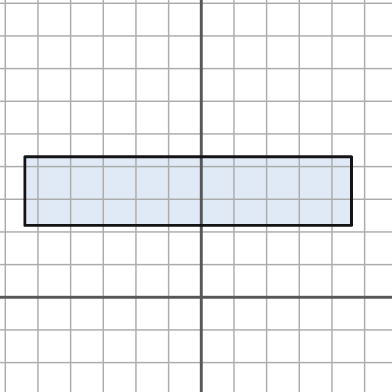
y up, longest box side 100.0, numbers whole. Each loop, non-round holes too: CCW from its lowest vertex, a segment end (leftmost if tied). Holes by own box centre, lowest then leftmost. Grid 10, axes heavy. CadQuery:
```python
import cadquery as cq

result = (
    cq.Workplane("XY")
    .moveTo(-54.0, 22.0)
    .lineTo(46.0, 22.0)
    .lineTo(46.0, 43.0)
    .lineTo(-54.0, 43.0)
    .close()
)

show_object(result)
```